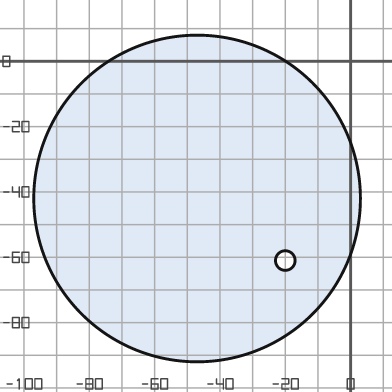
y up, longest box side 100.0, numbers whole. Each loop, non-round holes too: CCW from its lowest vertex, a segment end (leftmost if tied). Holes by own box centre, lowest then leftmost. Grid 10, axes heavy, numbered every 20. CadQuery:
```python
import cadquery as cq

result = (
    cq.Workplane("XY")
    .moveTo(-47.0, -42.0)
    .circle(50.0)
    .moveTo(-20.0, -61.0)
    .circle(3.0)
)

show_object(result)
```